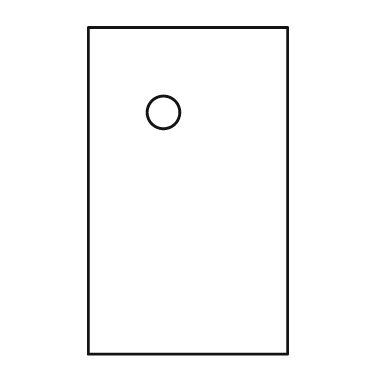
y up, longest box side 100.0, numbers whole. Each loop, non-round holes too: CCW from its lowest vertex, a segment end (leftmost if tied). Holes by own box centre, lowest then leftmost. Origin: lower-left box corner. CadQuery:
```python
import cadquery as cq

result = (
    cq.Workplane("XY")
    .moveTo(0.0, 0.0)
    .lineTo(61.0, 0.0)
    .lineTo(61.0, 100.0)
    .lineTo(0.0, 100.0)
    .close()
    .moveTo(23.0, 74.0)
    .circle(5.0)
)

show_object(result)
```